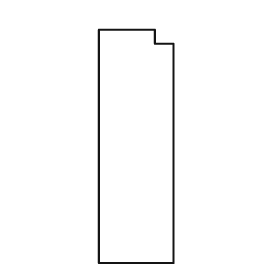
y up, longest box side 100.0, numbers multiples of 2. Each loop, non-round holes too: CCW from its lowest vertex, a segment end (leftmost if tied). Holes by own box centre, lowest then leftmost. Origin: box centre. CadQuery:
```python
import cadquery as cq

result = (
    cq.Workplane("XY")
    .moveTo(-16.0, -50.0)
    .lineTo(16.0, -50.0)
    .lineTo(16.0, 44.0)
    .lineTo(8.0, 44.0)
    .lineTo(8.0, 50.0)
    .lineTo(-16.0, 50.0)
    .close()
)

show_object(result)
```